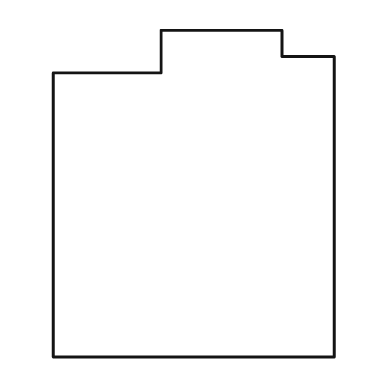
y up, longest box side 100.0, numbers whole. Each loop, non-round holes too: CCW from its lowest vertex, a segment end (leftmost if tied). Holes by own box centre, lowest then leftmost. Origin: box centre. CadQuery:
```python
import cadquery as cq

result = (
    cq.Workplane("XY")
    .moveTo(-43.0, -50.0)
    .lineTo(43.0, -50.0)
    .lineTo(43.0, 42.0)
    .lineTo(27.0, 42.0)
    .lineTo(27.0, 50.0)
    .lineTo(-10.0, 50.0)
    .lineTo(-10.0, 37.0)
    .lineTo(-43.0, 37.0)
    .close()
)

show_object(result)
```